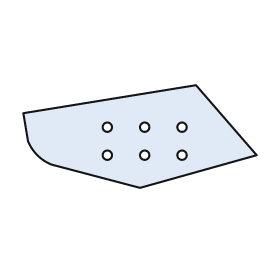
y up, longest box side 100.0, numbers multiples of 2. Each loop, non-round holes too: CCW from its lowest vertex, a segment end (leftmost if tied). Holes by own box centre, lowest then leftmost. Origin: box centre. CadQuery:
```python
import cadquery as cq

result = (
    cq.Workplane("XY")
    .moveTo(0.0, -22.0)
    .lineTo(50.0, -8.0)
    .lineTo(24.0, 22.0)
    .lineTo(-50.0, 10.0)
    .lineTo(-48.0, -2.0)
    .threePointArc((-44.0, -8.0), (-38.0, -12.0))
    .close()
    .moveTo(-14.0, -8.0)
    .circle(2.0)
    .moveTo(2.0, -8.0)
    .circle(2.0)
    .moveTo(18.0, -8.0)
    .circle(2.0)
    .moveTo(-14.0, 4.0)
    .circle(2.0)
    .moveTo(2.0, 4.0)
    .circle(2.0)
    .moveTo(18.0, 4.0)
    .circle(2.0)
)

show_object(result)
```